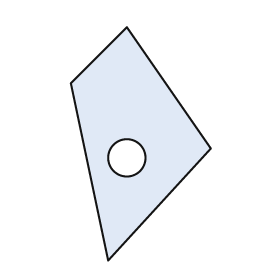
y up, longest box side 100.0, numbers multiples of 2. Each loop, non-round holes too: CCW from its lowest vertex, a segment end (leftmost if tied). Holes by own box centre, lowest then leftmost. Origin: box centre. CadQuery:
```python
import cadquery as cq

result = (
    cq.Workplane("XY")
    .moveTo(-14.0, -50.0)
    .lineTo(30.0, -2.0)
    .lineTo(-6.0, 50.0)
    .lineTo(-30.0, 26.0)
    .close()
    .moveTo(-6.0, -6.0)
    .circle(8.0)
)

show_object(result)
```